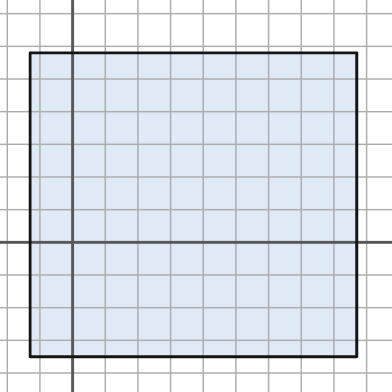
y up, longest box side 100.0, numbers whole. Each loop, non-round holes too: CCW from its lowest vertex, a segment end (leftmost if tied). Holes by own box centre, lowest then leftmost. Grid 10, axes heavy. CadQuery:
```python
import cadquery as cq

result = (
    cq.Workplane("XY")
    .moveTo(-13.0, -35.0)
    .lineTo(87.0, -35.0)
    .lineTo(87.0, 58.0)
    .lineTo(-13.0, 58.0)
    .close()
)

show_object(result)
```